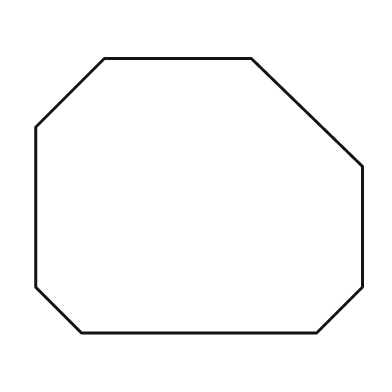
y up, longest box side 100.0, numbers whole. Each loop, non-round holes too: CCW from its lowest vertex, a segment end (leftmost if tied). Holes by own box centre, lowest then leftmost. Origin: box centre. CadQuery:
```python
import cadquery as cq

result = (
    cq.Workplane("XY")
    .moveTo(-36.0, -42.0)
    .lineTo(36.0, -42.0)
    .lineTo(50.0, -28.0)
    .lineTo(50.0, 9.0)
    .lineTo(16.0, 42.0)
    .lineTo(-29.0, 42.0)
    .lineTo(-50.0, 21.0)
    .lineTo(-50.0, -28.0)
    .close()
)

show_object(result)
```